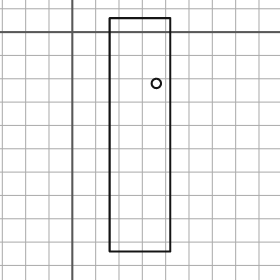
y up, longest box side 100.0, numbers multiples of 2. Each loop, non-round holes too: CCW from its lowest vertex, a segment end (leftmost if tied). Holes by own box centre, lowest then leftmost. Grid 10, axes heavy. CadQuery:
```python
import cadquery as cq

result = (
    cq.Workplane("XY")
    .moveTo(16.0, -94.0)
    .lineTo(42.0, -94.0)
    .lineTo(42.0, 6.0)
    .lineTo(16.0, 6.0)
    .close()
    .moveTo(36.0, -22.0)
    .circle(2.0)
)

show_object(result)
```